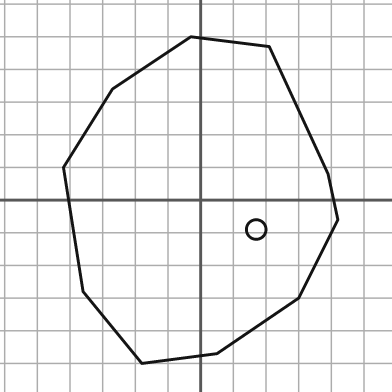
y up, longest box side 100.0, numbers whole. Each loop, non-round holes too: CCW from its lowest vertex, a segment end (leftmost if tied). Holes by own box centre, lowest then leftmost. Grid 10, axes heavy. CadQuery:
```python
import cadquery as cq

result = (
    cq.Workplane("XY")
    .moveTo(-18.0, -50.0)
    .lineTo(5.0, -47.0)
    .lineTo(30.0, -30.0)
    .lineTo(42.0, -6.0)
    .lineTo(39.0, 8.0)
    .lineTo(21.0, 47.0)
    .lineTo(-3.0, 50.0)
    .lineTo(-27.0, 34.0)
    .lineTo(-42.0, 10.0)
    .lineTo(-36.0, -28.0)
    .close()
    .moveTo(17.0, -9.0)
    .circle(3.0)
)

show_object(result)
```